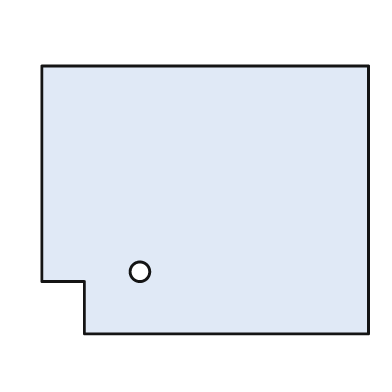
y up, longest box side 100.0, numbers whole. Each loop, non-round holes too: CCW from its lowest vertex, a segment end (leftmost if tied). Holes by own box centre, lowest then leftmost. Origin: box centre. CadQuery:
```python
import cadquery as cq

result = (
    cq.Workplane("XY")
    .moveTo(-37.0, -41.0)
    .lineTo(50.0, -41.0)
    .lineTo(50.0, 41.0)
    .lineTo(-50.0, 41.0)
    .lineTo(-50.0, -25.0)
    .lineTo(-37.0, -25.0)
    .close()
    .moveTo(-20.0, -22.0)
    .circle(3.0)
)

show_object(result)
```